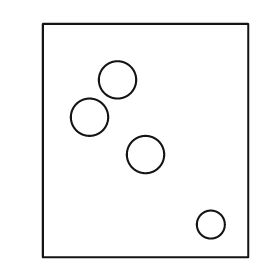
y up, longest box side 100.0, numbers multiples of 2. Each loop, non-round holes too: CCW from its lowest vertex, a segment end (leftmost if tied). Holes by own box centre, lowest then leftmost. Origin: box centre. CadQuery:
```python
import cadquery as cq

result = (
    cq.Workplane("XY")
    .moveTo(-44.0, -50.0)
    .lineTo(44.0, -50.0)
    .lineTo(44.0, 50.0)
    .lineTo(-44.0, 50.0)
    .close()
    .moveTo(28.0, -36.0)
    .circle(6.0)
    .moveTo(0.0, -6.0)
    .circle(8.0)
    .moveTo(-24.0, 10.0)
    .circle(8.0)
    .moveTo(-12.0, 26.0)
    .circle(8.0)
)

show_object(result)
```